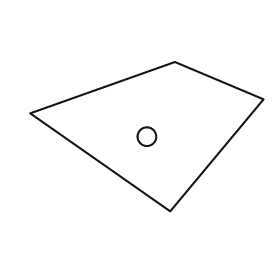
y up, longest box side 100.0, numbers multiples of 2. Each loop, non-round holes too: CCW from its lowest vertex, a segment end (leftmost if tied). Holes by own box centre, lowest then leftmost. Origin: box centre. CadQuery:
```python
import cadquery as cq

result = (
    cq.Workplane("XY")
    .moveTo(10.0, -32.0)
    .lineTo(50.0, 16.0)
    .lineTo(12.0, 32.0)
    .lineTo(-50.0, 10.0)
    .close()
    .moveTo(0.0, 0.0)
    .circle(4.0)
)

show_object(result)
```